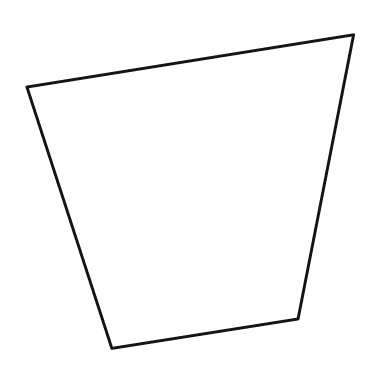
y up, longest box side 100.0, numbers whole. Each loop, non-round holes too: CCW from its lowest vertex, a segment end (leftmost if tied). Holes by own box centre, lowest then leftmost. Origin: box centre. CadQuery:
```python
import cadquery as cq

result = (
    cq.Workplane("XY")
    .moveTo(-24.0, -48.0)
    .lineTo(33.0, -39.0)
    .lineTo(50.0, 48.0)
    .lineTo(-50.0, 32.0)
    .close()
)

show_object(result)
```